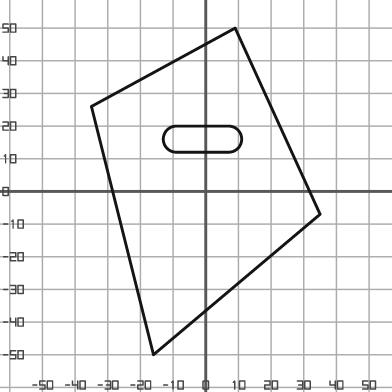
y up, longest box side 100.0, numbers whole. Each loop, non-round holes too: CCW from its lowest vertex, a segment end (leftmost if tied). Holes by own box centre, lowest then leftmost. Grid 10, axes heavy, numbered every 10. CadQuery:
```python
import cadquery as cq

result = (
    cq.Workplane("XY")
    .moveTo(-16.0, -50.0)
    .lineTo(35.0, -7.0)
    .lineTo(9.0, 50.0)
    .lineTo(-35.0, 26.0)
    .close()
    .moveTo(-9.0, 12.0)
    .lineTo(7.0, 12.0)
    .threePointArc((11.0, 16.0), (7.0, 20.0))
    .lineTo(-9.0, 20.0)
    .threePointArc((-13.0, 16.0), (-9.0, 12.0))
    .close()
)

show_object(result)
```